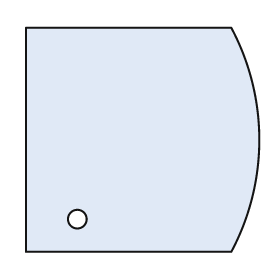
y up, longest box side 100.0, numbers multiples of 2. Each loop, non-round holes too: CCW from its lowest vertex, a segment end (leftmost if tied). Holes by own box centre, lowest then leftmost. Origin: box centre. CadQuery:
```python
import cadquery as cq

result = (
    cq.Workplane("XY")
    .moveTo(-50.0, -48.0)
    .lineTo(38.0, -48.0)
    .threePointArc((50.0, 0.0), (38.0, 48.0))
    .lineTo(-50.0, 48.0)
    .close()
    .moveTo(-28.0, -34.0)
    .circle(4.0)
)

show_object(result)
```